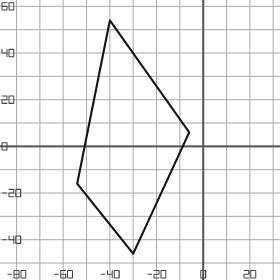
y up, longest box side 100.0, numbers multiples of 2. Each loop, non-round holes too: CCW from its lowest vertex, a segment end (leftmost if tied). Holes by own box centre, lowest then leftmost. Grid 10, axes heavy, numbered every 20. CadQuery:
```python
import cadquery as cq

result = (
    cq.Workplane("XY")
    .moveTo(-30.0, -46.0)
    .lineTo(-6.0, 6.0)
    .lineTo(-40.0, 54.0)
    .lineTo(-54.0, -16.0)
    .close()
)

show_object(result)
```